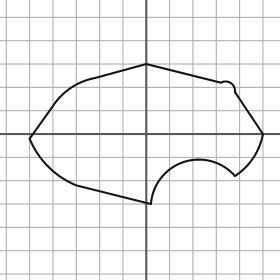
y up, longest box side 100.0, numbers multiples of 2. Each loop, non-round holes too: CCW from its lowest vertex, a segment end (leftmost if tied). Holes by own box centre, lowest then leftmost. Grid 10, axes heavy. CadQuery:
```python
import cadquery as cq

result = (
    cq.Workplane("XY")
    .moveTo(2.0, -30.0)
    .threePointArc((16.0, -12.0), (38.0, -18.0))
    .threePointArc((46.0, -10.0), (50.0, 0.0))
    .lineTo(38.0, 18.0)
    .threePointArc((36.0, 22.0), (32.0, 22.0))
    .lineTo(0.0, 30.0)
    .lineTo(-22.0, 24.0)
    .threePointArc((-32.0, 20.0), (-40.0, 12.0))
    .lineTo(-50.0, -2.0)
    .threePointArc((-42.0, -14.0), (-30.0, -22.0))
    .close()
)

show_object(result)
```